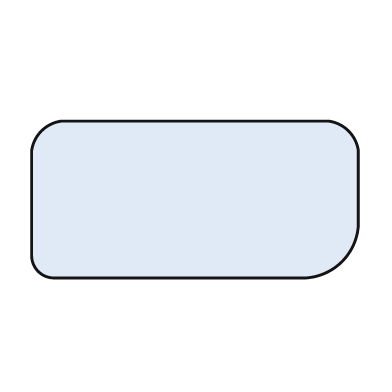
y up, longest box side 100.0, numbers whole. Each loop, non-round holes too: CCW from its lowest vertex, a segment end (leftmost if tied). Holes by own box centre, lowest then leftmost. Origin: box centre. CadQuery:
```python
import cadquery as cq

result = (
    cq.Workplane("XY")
    .moveTo(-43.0, -24.0)
    .lineTo(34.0, -24.0)
    .threePointArc((45.0, -19.0), (50.0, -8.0))
    .lineTo(50.0, 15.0)
    .threePointArc((47.0, 21.0), (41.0, 24.0))
    .lineTo(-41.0, 24.0)
    .threePointArc((-47.0, 21.0), (-50.0, 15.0))
    .lineTo(-50.0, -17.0)
    .threePointArc((-48.0, -22.0), (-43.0, -24.0))
    .close()
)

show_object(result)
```